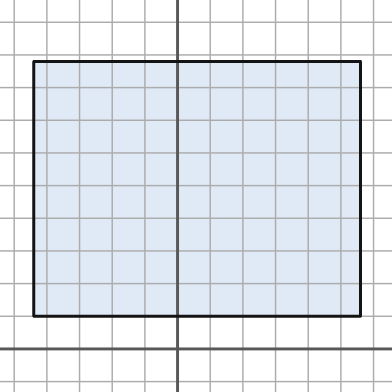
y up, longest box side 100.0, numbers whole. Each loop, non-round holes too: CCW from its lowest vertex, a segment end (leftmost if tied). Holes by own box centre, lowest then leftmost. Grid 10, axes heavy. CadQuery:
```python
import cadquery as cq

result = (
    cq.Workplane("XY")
    .moveTo(-44.0, 10.0)
    .lineTo(56.0, 10.0)
    .lineTo(56.0, 88.0)
    .lineTo(-44.0, 88.0)
    .close()
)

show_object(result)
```